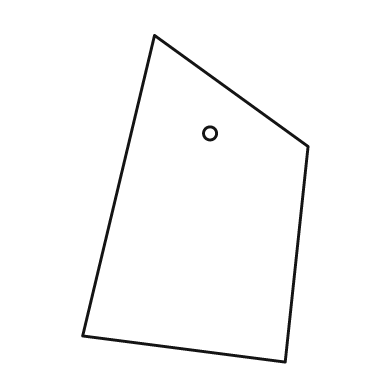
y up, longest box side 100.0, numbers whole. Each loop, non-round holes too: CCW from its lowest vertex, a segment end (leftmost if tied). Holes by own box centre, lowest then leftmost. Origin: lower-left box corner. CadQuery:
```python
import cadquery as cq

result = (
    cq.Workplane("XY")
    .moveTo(62.0, 0.0)
    .lineTo(69.0, 66.0)
    .lineTo(22.0, 100.0)
    .lineTo(0.0, 8.0)
    .close()
    .moveTo(39.0, 70.0)
    .circle(2.0)
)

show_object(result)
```